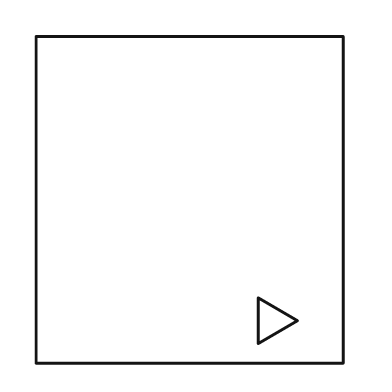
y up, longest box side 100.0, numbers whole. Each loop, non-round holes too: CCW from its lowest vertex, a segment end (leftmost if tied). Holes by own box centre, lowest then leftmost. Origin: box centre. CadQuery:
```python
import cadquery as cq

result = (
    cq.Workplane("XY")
    .moveTo(-47.0, -50.0)
    .lineTo(47.0, -50.0)
    .lineTo(47.0, 50.0)
    .lineTo(-47.0, 50.0)
    .close()
    .moveTo(21.0, -44.0)
    .lineTo(33.0, -37.0)
    .lineTo(21.0, -30.0)
    .close()
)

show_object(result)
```